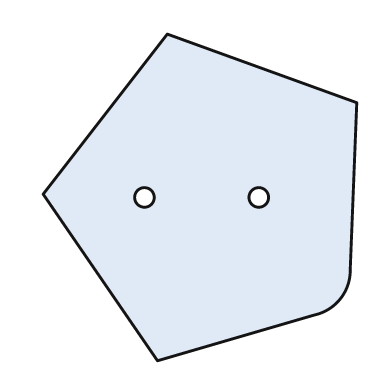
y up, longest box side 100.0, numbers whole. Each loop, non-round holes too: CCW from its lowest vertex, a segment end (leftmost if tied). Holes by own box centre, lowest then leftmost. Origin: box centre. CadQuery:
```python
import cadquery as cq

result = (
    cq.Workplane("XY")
    .moveTo(-13.0, -50.0)
    .lineTo(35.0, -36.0)
    .threePointArc((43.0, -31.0), (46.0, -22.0))
    .lineTo(48.0, 29.0)
    .lineTo(-10.0, 50.0)
    .lineTo(-48.0, 1.0)
    .close()
    .moveTo(-17.0, 0.0)
    .circle(3.0)
    .moveTo(18.0, 0.0)
    .circle(3.0)
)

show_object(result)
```